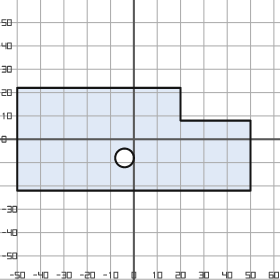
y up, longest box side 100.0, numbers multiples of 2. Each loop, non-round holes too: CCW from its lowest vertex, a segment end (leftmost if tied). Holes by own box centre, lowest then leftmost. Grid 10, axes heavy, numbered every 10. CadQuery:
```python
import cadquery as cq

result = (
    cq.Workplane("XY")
    .moveTo(-50.0, -22.0)
    .lineTo(50.0, -22.0)
    .lineTo(50.0, 8.0)
    .lineTo(20.0, 8.0)
    .lineTo(20.0, 22.0)
    .lineTo(-50.0, 22.0)
    .close()
    .moveTo(-4.0, -8.0)
    .circle(4.0)
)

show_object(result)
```